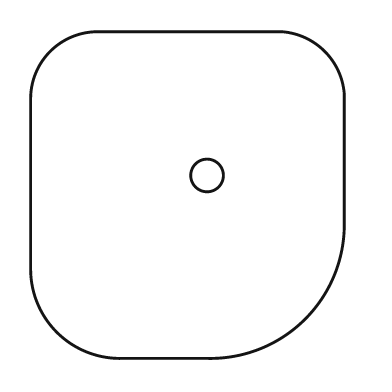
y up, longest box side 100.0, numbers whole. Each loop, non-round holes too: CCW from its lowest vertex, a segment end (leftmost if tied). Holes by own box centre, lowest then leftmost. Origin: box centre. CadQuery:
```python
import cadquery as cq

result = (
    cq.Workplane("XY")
    .moveTo(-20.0, -50.0)
    .lineTo(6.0, -50.0)
    .threePointArc((36.0, -38.0), (48.0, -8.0))
    .lineTo(48.0, 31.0)
    .threePointArc((42.0, 44.0), (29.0, 50.0))
    .lineTo(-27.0, 50.0)
    .threePointArc((-42.0, 44.0), (-48.0, 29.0))
    .lineTo(-48.0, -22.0)
    .threePointArc((-40.0, -42.0), (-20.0, -50.0))
    .close()
    .moveTo(6.0, 6.0)
    .circle(5.0)
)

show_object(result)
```